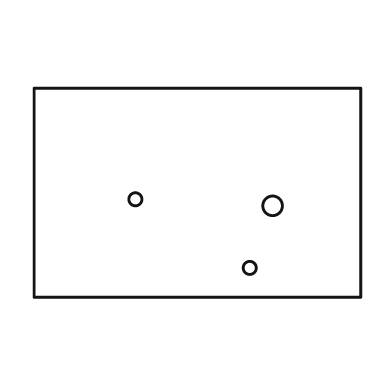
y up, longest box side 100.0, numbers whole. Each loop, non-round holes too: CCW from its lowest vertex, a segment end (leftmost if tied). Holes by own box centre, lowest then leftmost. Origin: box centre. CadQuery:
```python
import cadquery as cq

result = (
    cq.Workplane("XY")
    .moveTo(-50.0, -32.0)
    .lineTo(50.0, -32.0)
    .lineTo(50.0, 32.0)
    .lineTo(-50.0, 32.0)
    .close()
    .moveTo(16.0, -23.0)
    .circle(2.0)
    .moveTo(23.0, -4.0)
    .circle(3.0)
    .moveTo(-19.0, -2.0)
    .circle(2.0)
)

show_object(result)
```